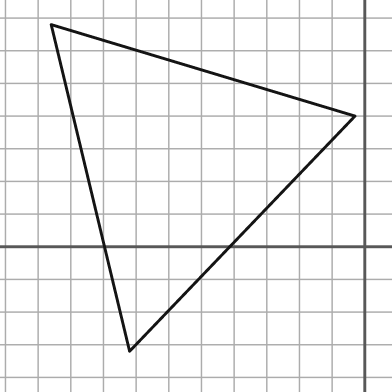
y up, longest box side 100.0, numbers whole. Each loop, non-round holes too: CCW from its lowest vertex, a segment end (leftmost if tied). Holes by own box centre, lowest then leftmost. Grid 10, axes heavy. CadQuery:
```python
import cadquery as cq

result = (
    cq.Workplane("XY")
    .moveTo(-72.0, -32.0)
    .lineTo(-3.0, 40.0)
    .lineTo(-96.0, 68.0)
    .close()
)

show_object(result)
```